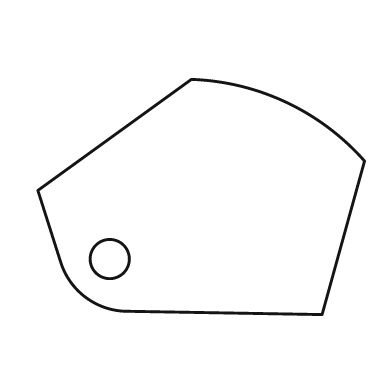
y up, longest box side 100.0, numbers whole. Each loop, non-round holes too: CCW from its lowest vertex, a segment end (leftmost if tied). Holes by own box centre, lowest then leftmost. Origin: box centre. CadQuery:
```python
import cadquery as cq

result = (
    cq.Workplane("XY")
    .moveTo(37.0, -36.0)
    .lineTo(50.0, 11.0)
    .threePointArc((26.0, 29.0), (-3.0, 36.0))
    .lineTo(-50.0, 2.0)
    .lineTo(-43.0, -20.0)
    .threePointArc((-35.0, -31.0), (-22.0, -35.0))
    .close()
    .moveTo(-28.0, -19.0)
    .circle(6.0)
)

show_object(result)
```